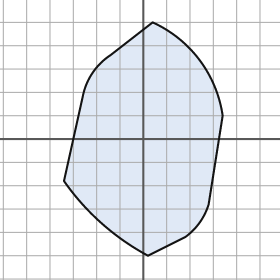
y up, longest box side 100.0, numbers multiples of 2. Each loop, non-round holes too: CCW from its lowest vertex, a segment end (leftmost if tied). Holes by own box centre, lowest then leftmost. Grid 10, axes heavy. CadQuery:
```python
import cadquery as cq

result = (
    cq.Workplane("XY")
    .moveTo(2.0, -50.0)
    .lineTo(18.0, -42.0)
    .threePointArc((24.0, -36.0), (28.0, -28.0))
    .lineTo(34.0, 10.0)
    .threePointArc((24.0, 34.0), (4.0, 50.0))
    .lineTo(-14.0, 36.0)
    .threePointArc((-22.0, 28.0), (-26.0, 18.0))
    .lineTo(-34.0, -18.0)
    .threePointArc((-18.0, -36.0), (2.0, -50.0))
    .close()
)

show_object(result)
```